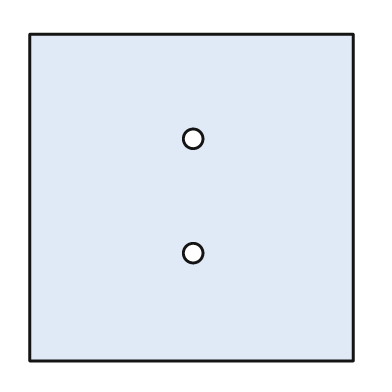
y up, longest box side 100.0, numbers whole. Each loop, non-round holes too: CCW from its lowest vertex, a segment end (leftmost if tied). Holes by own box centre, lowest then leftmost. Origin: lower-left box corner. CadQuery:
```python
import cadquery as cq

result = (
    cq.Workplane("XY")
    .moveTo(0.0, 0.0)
    .lineTo(99.0, 0.0)
    .lineTo(99.0, 100.0)
    .lineTo(0.0, 100.0)
    .close()
    .moveTo(50.0, 33.0)
    .circle(3.0)
    .moveTo(50.0, 68.0)
    .circle(3.0)
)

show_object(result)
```